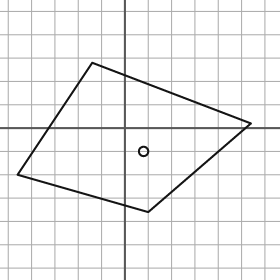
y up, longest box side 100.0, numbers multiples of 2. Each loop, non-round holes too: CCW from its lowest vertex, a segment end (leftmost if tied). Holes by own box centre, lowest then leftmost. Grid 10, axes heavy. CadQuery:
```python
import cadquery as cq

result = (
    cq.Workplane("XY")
    .moveTo(10.0, -36.0)
    .lineTo(54.0, 2.0)
    .lineTo(-14.0, 28.0)
    .lineTo(-46.0, -20.0)
    .close()
    .moveTo(8.0, -10.0)
    .circle(2.0)
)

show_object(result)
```